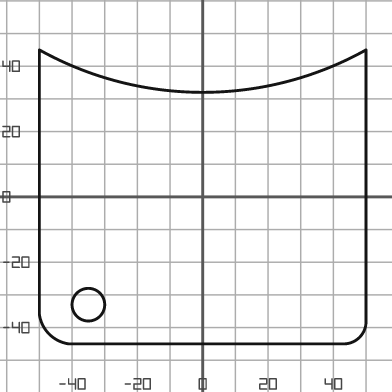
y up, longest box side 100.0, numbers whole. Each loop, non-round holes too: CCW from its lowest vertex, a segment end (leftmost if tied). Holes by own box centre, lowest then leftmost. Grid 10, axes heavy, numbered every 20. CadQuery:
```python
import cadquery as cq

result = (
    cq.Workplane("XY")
    .moveTo(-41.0, -45.0)
    .lineTo(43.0, -45.0)
    .threePointArc((48.0, -43.0), (50.0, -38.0))
    .lineTo(50.0, 45.0)
    .threePointArc((0.0, 32.0), (-50.0, 45.0))
    .lineTo(-50.0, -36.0)
    .threePointArc((-47.0, -42.0), (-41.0, -45.0))
    .close()
    .moveTo(-35.0, -33.0)
    .circle(5.0)
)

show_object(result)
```